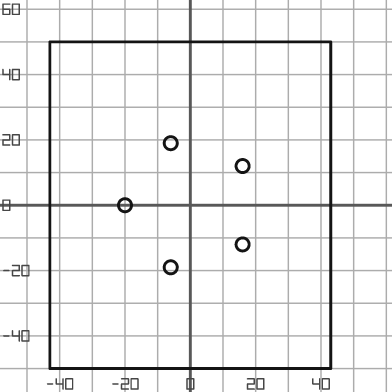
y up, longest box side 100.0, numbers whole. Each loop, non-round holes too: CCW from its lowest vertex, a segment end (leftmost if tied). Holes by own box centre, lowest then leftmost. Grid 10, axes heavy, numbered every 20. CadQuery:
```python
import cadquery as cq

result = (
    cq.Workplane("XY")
    .moveTo(-43.0, -50.0)
    .lineTo(43.0, -50.0)
    .lineTo(43.0, 50.0)
    .lineTo(-43.0, 50.0)
    .close()
    .moveTo(-6.0, -19.0)
    .circle(2.0)
    .moveTo(16.0, -12.0)
    .circle(2.0)
    .moveTo(-20.0, 0.0)
    .circle(2.0)
    .moveTo(16.0, 12.0)
    .circle(2.0)
    .moveTo(-6.0, 19.0)
    .circle(2.0)
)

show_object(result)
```